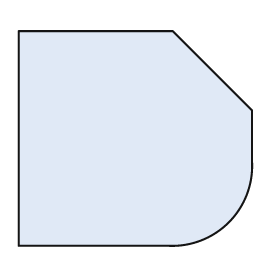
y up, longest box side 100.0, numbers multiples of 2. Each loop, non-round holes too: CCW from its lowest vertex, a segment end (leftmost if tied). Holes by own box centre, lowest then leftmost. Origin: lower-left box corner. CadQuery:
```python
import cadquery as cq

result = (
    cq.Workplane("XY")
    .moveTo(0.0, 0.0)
    .lineTo(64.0, 0.0)
    .threePointArc((90.0, 10.0), (100.0, 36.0))
    .lineTo(100.0, 58.0)
    .lineTo(66.0, 92.0)
    .lineTo(0.0, 92.0)
    .close()
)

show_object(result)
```